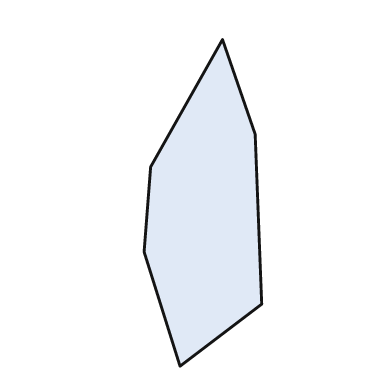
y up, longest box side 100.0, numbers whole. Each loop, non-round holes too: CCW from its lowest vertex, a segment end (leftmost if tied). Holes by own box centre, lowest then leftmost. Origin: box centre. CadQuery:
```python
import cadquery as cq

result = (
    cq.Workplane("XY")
    .moveTo(-7.0, -50.0)
    .lineTo(18.0, -31.0)
    .lineTo(16.0, 21.0)
    .lineTo(6.0, 50.0)
    .lineTo(-16.0, 11.0)
    .lineTo(-18.0, -15.0)
    .close()
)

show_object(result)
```